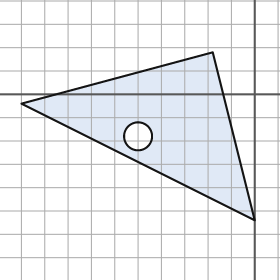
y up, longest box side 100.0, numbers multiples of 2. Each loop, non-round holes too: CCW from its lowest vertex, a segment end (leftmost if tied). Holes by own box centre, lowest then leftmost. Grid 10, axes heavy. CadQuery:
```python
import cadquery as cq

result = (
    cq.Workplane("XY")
    .moveTo(0.0, -54.0)
    .lineTo(-18.0, 18.0)
    .lineTo(-100.0, -4.0)
    .close()
    .moveTo(-50.0, -18.0)
    .circle(6.0)
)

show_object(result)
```